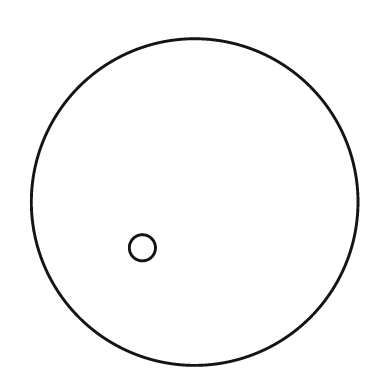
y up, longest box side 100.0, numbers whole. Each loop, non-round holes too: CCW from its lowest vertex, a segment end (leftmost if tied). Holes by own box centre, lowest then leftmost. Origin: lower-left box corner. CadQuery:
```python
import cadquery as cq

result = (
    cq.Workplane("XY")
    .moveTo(50.0, 50.0)
    .circle(50.0)
    .moveTo(34.0, 36.0)
    .circle(4.0)
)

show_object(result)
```